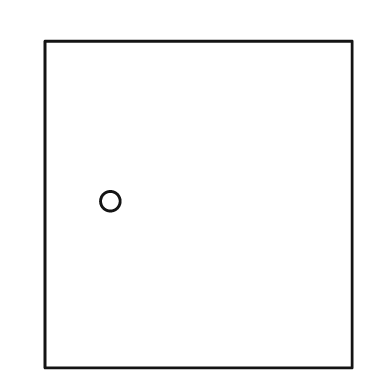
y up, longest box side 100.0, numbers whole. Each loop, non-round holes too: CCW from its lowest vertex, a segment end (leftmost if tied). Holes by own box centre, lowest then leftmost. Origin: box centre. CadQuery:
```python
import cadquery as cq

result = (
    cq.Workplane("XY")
    .moveTo(-47.0, -50.0)
    .lineTo(47.0, -50.0)
    .lineTo(47.0, 50.0)
    .lineTo(-47.0, 50.0)
    .close()
    .moveTo(-27.0, 1.0)
    .circle(3.0)
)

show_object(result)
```